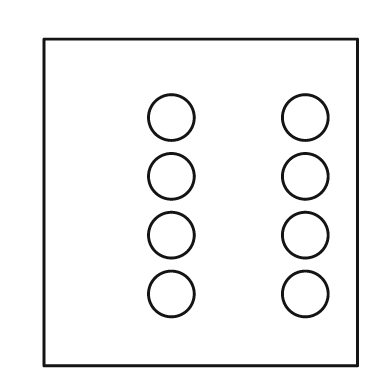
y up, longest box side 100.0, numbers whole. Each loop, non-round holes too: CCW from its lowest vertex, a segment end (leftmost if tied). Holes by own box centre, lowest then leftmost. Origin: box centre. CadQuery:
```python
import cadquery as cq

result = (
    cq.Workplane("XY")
    .moveTo(-48.0, -50.0)
    .lineTo(48.0, -50.0)
    .lineTo(48.0, 50.0)
    .lineTo(-48.0, 50.0)
    .close()
    .moveTo(-9.0, -28.0)
    .circle(7.0)
    .moveTo(32.0, -28.0)
    .circle(7.0)
    .moveTo(-9.0, -10.0)
    .circle(7.0)
    .moveTo(32.0, -10.0)
    .circle(7.0)
    .moveTo(-9.0, 8.0)
    .circle(7.0)
    .moveTo(32.0, 8.0)
    .circle(7.0)
    .moveTo(-9.0, 26.0)
    .circle(7.0)
    .moveTo(32.0, 26.0)
    .circle(7.0)
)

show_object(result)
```